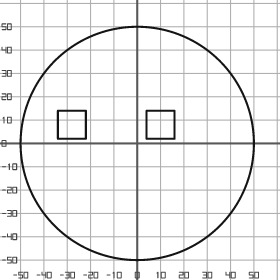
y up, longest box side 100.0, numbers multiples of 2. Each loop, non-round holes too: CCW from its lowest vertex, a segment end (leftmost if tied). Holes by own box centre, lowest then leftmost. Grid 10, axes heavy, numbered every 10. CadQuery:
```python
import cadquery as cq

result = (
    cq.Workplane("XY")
    .moveTo(0.0, 0.0)
    .circle(50.0)
    .moveTo(-34.0, 2.0)
    .lineTo(-22.0, 2.0)
    .lineTo(-22.0, 14.0)
    .lineTo(-34.0, 14.0)
    .close()
    .moveTo(4.0, 2.0)
    .lineTo(16.0, 2.0)
    .lineTo(16.0, 14.0)
    .lineTo(4.0, 14.0)
    .close()
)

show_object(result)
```